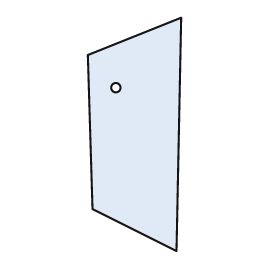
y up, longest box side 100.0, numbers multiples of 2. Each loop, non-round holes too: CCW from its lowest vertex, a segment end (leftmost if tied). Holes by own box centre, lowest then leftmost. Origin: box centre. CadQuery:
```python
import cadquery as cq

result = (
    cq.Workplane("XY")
    .moveTo(18.0, -50.0)
    .lineTo(20.0, 50.0)
    .lineTo(-20.0, 34.0)
    .lineTo(-18.0, -32.0)
    .close()
    .moveTo(-8.0, 20.0)
    .circle(2.0)
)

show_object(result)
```